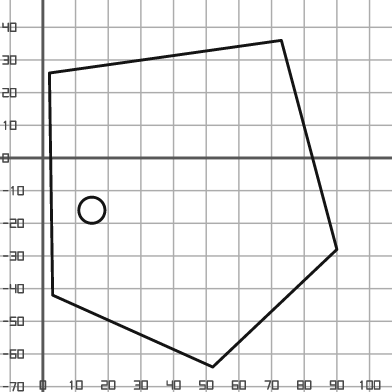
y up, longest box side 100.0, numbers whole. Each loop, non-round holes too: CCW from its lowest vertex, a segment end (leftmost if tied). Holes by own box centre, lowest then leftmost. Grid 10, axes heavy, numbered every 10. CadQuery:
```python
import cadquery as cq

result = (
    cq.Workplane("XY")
    .moveTo(52.0, -64.0)
    .lineTo(90.0, -28.0)
    .lineTo(73.0, 36.0)
    .lineTo(2.0, 26.0)
    .lineTo(3.0, -42.0)
    .close()
    .moveTo(15.0, -16.0)
    .circle(4.0)
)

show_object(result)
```